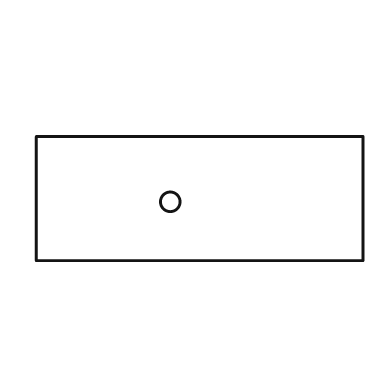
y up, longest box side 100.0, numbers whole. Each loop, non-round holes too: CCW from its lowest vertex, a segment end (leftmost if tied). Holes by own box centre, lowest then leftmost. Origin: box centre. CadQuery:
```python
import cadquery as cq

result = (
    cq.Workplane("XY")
    .moveTo(-50.0, -19.0)
    .lineTo(50.0, -19.0)
    .lineTo(50.0, 19.0)
    .lineTo(-50.0, 19.0)
    .close()
    .moveTo(-9.0, -1.0)
    .circle(3.0)
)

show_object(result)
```